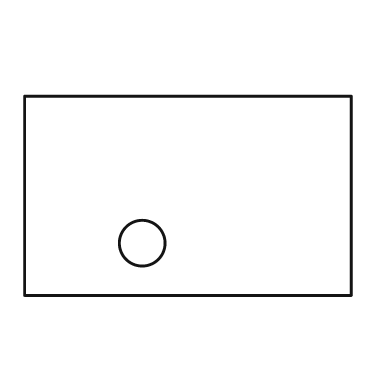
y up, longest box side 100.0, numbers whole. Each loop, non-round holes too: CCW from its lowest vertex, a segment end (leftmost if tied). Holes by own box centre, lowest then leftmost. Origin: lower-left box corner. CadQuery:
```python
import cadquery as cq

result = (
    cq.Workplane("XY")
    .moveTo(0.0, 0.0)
    .lineTo(100.0, 0.0)
    .lineTo(100.0, 61.0)
    .lineTo(0.0, 61.0)
    .close()
    .moveTo(36.0, 16.0)
    .circle(7.0)
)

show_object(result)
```